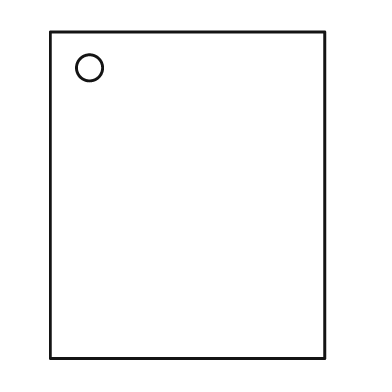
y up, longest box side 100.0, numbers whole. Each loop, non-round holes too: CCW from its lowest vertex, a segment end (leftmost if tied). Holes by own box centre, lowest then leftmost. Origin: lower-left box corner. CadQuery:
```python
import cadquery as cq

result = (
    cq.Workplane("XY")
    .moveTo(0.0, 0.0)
    .lineTo(84.0, 0.0)
    .lineTo(84.0, 100.0)
    .lineTo(0.0, 100.0)
    .close()
    .moveTo(12.0, 89.0)
    .circle(4.0)
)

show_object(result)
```